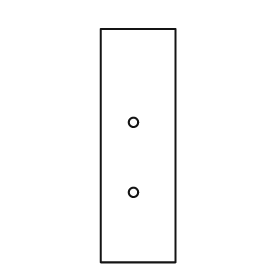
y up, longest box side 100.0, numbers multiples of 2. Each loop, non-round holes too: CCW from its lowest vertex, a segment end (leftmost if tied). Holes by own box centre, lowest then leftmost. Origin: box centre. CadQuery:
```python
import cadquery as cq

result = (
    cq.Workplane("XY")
    .moveTo(-16.0, -50.0)
    .lineTo(16.0, -50.0)
    .lineTo(16.0, 50.0)
    .lineTo(-16.0, 50.0)
    .close()
    .moveTo(-2.0, -20.0)
    .circle(2.0)
    .moveTo(-2.0, 10.0)
    .circle(2.0)
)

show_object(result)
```